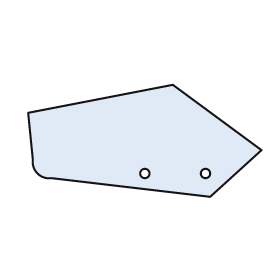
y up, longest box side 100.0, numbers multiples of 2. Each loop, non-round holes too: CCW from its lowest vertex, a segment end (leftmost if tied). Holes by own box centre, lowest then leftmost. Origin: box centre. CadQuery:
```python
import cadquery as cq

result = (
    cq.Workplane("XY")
    .moveTo(28.0, -24.0)
    .lineTo(50.0, -4.0)
    .lineTo(12.0, 24.0)
    .lineTo(-50.0, 12.0)
    .lineTo(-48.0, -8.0)
    .threePointArc((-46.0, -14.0), (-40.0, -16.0))
    .close()
    .moveTo(0.0, -14.0)
    .circle(2.0)
    .moveTo(26.0, -14.0)
    .circle(2.0)
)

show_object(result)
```